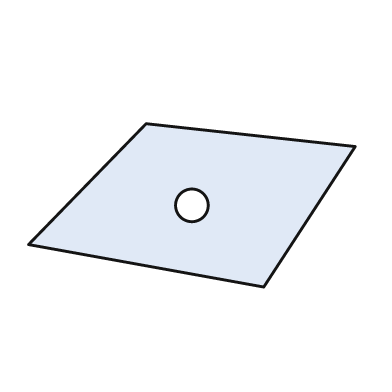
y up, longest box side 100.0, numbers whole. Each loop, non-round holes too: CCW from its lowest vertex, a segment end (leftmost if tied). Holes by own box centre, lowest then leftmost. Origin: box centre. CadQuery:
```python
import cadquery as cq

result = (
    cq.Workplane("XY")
    .moveTo(22.0, -25.0)
    .lineTo(50.0, 18.0)
    .lineTo(-14.0, 25.0)
    .lineTo(-50.0, -12.0)
    .close()
    .moveTo(0.0, 0.0)
    .circle(5.0)
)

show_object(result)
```